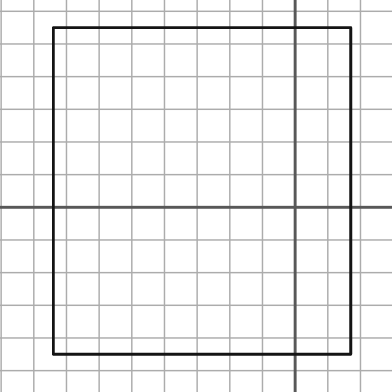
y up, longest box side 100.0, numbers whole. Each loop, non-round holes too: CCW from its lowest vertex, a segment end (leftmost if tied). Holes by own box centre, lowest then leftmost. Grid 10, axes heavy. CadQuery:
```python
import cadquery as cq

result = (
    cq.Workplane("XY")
    .moveTo(-74.0, -45.0)
    .lineTo(17.0, -45.0)
    .lineTo(17.0, 55.0)
    .lineTo(-74.0, 55.0)
    .close()
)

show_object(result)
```